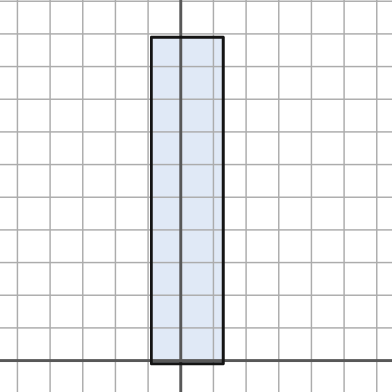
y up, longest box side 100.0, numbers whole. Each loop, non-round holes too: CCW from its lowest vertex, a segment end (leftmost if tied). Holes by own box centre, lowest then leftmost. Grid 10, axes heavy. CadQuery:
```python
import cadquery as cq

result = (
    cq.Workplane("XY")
    .moveTo(-9.0, -1.0)
    .lineTo(13.0, -1.0)
    .lineTo(13.0, 99.0)
    .lineTo(-9.0, 99.0)
    .close()
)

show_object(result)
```